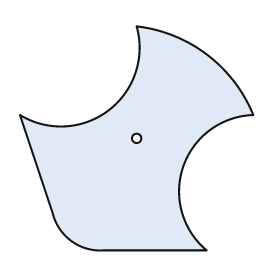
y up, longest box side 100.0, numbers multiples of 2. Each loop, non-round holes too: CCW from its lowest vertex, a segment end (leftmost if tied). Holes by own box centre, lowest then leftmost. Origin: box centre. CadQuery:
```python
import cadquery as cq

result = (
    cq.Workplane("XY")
    .moveTo(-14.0, -48.0)
    .lineTo(30.0, -48.0)
    .threePointArc((20.0, -12.0), (50.0, 10.0))
    .threePointArc((30.0, 36.0), (0.0, 48.0))
    .threePointArc((-12.0, 12.0), (-50.0, 10.0))
    .lineTo(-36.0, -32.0)
    .threePointArc((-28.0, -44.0), (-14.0, -48.0))
    .close()
    .moveTo(0.0, 0.0)
    .circle(2.0)
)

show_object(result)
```